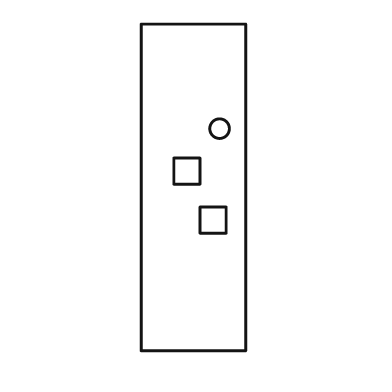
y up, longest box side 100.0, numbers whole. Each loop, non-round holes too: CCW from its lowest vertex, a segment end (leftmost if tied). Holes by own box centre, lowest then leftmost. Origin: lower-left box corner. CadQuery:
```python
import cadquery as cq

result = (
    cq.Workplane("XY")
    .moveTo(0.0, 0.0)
    .lineTo(32.0, 0.0)
    .lineTo(32.0, 100.0)
    .lineTo(0.0, 100.0)
    .close()
    .moveTo(18.0, 36.0)
    .lineTo(26.0, 36.0)
    .lineTo(26.0, 44.0)
    .lineTo(18.0, 44.0)
    .close()
    .moveTo(10.0, 51.0)
    .lineTo(18.0, 51.0)
    .lineTo(18.0, 59.0)
    .lineTo(10.0, 59.0)
    .close()
    .moveTo(24.0, 68.0)
    .circle(3.0)
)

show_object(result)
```